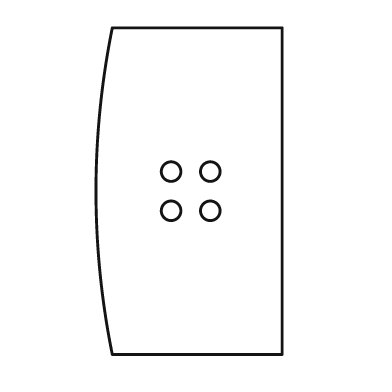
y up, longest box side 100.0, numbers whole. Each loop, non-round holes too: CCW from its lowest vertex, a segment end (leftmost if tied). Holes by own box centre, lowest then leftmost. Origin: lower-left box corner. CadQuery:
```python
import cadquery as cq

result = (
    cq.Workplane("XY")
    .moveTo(5.0, 0.0)
    .lineTo(57.0, 0.0)
    .lineTo(57.0, 100.0)
    .lineTo(5.0, 100.0)
    .threePointArc((0.0, 50.0), (5.0, 0.0))
    .close()
    .moveTo(23.0, 44.0)
    .circle(3.0)
    .moveTo(35.0, 44.0)
    .circle(3.0)
    .moveTo(23.0, 56.0)
    .circle(3.0)
    .moveTo(35.0, 56.0)
    .circle(3.0)
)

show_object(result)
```